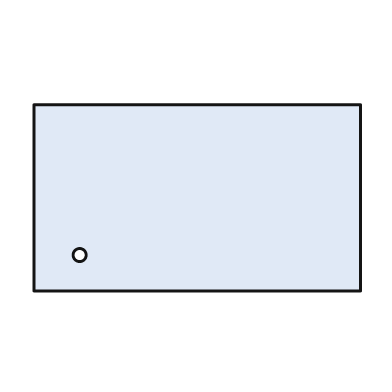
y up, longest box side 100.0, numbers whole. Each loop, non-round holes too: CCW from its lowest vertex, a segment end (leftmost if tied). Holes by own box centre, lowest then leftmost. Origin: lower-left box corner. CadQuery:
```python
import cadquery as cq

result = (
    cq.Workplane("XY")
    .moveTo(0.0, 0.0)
    .lineTo(100.0, 0.0)
    .lineTo(100.0, 57.0)
    .lineTo(0.0, 57.0)
    .close()
    .moveTo(14.0, 11.0)
    .circle(2.0)
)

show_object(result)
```